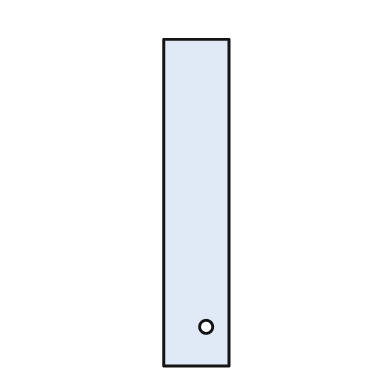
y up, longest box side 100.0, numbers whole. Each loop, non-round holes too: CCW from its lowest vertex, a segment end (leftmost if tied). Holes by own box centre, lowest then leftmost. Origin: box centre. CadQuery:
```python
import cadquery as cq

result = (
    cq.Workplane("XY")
    .moveTo(-10.0, -50.0)
    .lineTo(10.0, -50.0)
    .lineTo(10.0, 50.0)
    .lineTo(-10.0, 50.0)
    .close()
    .moveTo(3.0, -38.0)
    .circle(2.0)
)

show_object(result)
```